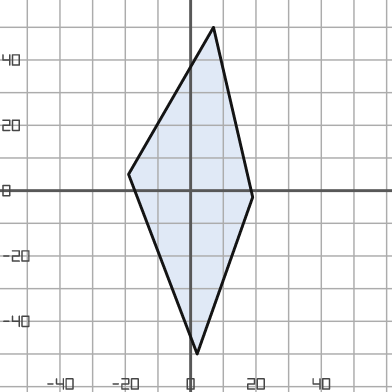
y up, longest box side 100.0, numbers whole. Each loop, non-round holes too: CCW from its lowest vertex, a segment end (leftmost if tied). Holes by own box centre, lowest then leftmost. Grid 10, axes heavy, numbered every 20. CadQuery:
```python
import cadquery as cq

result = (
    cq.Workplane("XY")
    .moveTo(2.0, -50.0)
    .lineTo(19.0, -2.0)
    .lineTo(7.0, 50.0)
    .lineTo(-19.0, 5.0)
    .close()
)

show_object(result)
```